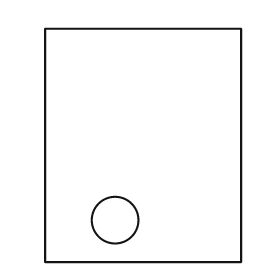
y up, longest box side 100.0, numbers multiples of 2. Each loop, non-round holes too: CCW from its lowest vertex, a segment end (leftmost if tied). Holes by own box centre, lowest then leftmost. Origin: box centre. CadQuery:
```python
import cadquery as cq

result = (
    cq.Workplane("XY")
    .moveTo(-42.0, -50.0)
    .lineTo(42.0, -50.0)
    .lineTo(42.0, 50.0)
    .lineTo(-42.0, 50.0)
    .close()
    .moveTo(-12.0, -32.0)
    .circle(10.0)
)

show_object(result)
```